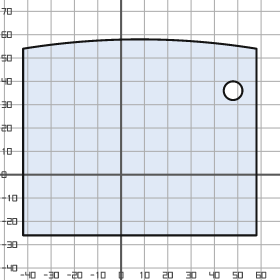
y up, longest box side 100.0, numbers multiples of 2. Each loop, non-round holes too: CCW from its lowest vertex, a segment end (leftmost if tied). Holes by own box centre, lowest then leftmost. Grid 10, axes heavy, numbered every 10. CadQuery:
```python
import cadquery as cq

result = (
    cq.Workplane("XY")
    .moveTo(-42.0, -26.0)
    .lineTo(58.0, -26.0)
    .lineTo(58.0, 54.0)
    .threePointArc((8.0, 58.0), (-42.0, 54.0))
    .close()
    .moveTo(48.0, 36.0)
    .circle(4.0)
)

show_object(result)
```